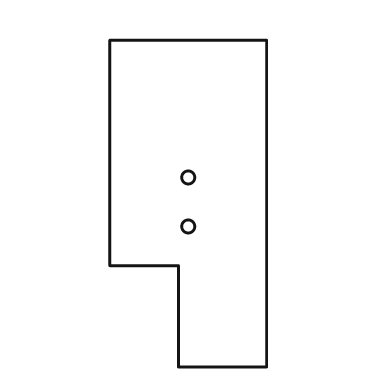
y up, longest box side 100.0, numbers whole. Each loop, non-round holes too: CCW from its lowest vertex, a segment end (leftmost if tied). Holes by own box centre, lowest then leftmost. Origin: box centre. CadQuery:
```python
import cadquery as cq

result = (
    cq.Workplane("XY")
    .moveTo(-3.0, -50.0)
    .lineTo(24.0, -50.0)
    .lineTo(24.0, 50.0)
    .lineTo(-24.0, 50.0)
    .lineTo(-24.0, -19.0)
    .lineTo(-3.0, -19.0)
    .close()
    .moveTo(0.0, -7.0)
    .circle(2.0)
    .moveTo(0.0, 8.0)
    .circle(2.0)
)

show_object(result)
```